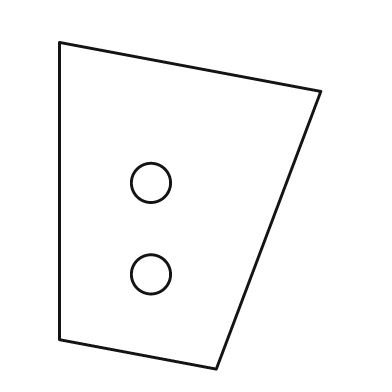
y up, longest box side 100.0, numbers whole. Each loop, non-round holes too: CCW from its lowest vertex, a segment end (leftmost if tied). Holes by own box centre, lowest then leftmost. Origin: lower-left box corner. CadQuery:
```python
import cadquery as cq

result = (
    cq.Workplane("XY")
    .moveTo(48.0, 0.0)
    .lineTo(80.0, 85.0)
    .lineTo(0.0, 100.0)
    .lineTo(0.0, 9.0)
    .close()
    .moveTo(28.0, 29.0)
    .circle(6.0)
    .moveTo(28.0, 57.0)
    .circle(6.0)
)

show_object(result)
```